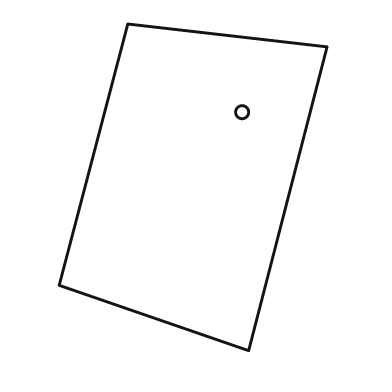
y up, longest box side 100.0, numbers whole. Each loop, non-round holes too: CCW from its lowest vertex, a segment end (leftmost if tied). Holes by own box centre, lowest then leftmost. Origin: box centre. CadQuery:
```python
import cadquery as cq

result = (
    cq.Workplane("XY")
    .moveTo(17.0, -50.0)
    .lineTo(41.0, 43.0)
    .lineTo(-20.0, 50.0)
    .lineTo(-41.0, -30.0)
    .close()
    .moveTo(15.0, 23.0)
    .circle(2.0)
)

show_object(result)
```